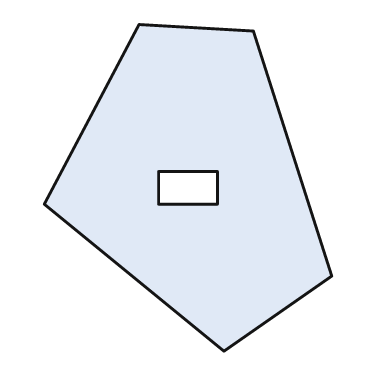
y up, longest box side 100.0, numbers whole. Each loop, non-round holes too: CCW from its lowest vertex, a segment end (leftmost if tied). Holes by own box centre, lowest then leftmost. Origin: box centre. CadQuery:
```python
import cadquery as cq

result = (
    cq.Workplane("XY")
    .moveTo(11.0, -50.0)
    .lineTo(44.0, -27.0)
    .lineTo(20.0, 48.0)
    .lineTo(-15.0, 50.0)
    .lineTo(-44.0, -5.0)
    .close()
    .moveTo(-9.0, -5.0)
    .lineTo(9.0, -5.0)
    .lineTo(9.0, 5.0)
    .lineTo(-9.0, 5.0)
    .close()
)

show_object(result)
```